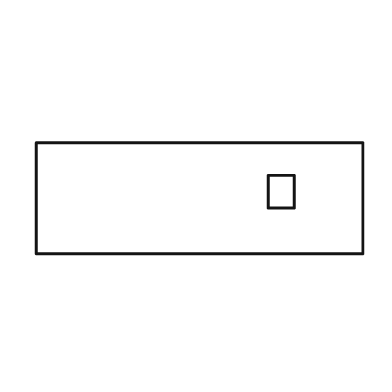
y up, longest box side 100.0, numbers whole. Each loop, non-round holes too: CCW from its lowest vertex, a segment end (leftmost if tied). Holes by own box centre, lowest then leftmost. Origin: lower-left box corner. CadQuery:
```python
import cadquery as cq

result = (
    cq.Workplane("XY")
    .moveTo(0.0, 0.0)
    .lineTo(100.0, 0.0)
    .lineTo(100.0, 34.0)
    .lineTo(0.0, 34.0)
    .close()
    .moveTo(71.0, 14.0)
    .lineTo(79.0, 14.0)
    .lineTo(79.0, 24.0)
    .lineTo(71.0, 24.0)
    .close()
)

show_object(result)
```